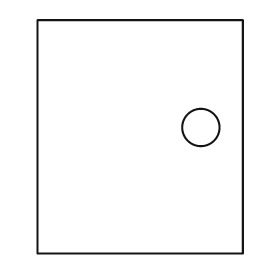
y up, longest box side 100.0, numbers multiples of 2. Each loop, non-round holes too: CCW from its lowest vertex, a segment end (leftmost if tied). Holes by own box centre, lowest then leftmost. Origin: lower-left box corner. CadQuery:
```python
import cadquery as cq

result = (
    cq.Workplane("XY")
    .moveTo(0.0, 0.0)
    .lineTo(88.0, 0.0)
    .lineTo(88.0, 100.0)
    .lineTo(0.0, 100.0)
    .close()
    .moveTo(70.0, 54.0)
    .circle(8.0)
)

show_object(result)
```